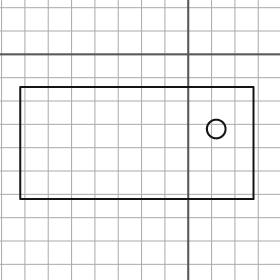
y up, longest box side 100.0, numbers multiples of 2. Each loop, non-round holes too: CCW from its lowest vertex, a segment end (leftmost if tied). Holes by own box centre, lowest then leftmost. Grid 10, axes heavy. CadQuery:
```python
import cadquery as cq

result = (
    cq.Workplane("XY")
    .moveTo(-72.0, -62.0)
    .lineTo(28.0, -62.0)
    .lineTo(28.0, -14.0)
    .lineTo(-72.0, -14.0)
    .close()
    .moveTo(12.0, -32.0)
    .circle(4.0)
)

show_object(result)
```